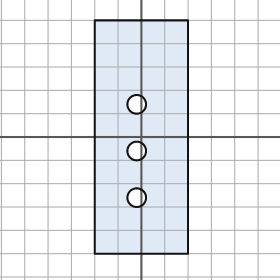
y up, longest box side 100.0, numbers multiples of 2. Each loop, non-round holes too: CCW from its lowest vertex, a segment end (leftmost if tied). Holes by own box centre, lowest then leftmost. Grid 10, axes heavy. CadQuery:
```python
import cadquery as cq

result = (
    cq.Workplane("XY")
    .moveTo(-20.0, -50.0)
    .lineTo(20.0, -50.0)
    .lineTo(20.0, 50.0)
    .lineTo(-20.0, 50.0)
    .close()
    .moveTo(-2.0, -26.0)
    .circle(4.0)
    .moveTo(-2.0, -6.0)
    .circle(4.0)
    .moveTo(-2.0, 14.0)
    .circle(4.0)
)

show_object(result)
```